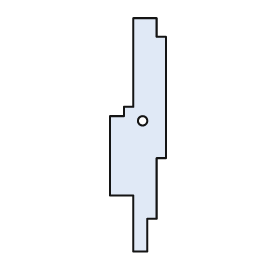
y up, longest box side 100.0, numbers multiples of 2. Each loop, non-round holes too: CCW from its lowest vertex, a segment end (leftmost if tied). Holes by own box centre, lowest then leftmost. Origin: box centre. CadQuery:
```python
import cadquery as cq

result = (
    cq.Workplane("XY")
    .moveTo(-2.0, -50.0)
    .lineTo(4.0, -50.0)
    .lineTo(4.0, -36.0)
    .lineTo(8.0, -36.0)
    .lineTo(8.0, -10.0)
    .lineTo(12.0, -10.0)
    .lineTo(12.0, 42.0)
    .lineTo(8.0, 42.0)
    .lineTo(8.0, 50.0)
    .lineTo(-2.0, 50.0)
    .lineTo(-2.0, 12.0)
    .lineTo(-6.0, 12.0)
    .lineTo(-6.0, 8.0)
    .lineTo(-12.0, 8.0)
    .lineTo(-12.0, -26.0)
    .lineTo(-2.0, -26.0)
    .close()
    .moveTo(2.0, 6.0)
    .circle(2.0)
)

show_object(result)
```